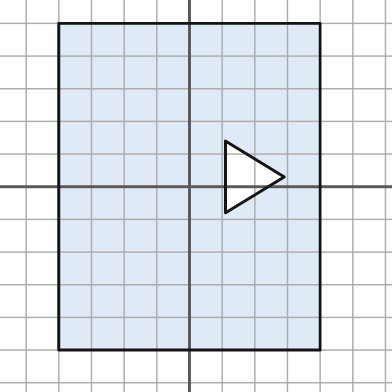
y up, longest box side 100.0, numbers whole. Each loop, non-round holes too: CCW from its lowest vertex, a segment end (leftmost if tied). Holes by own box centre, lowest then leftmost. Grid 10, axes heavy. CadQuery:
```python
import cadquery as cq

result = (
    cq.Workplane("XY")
    .moveTo(-40.0, -50.0)
    .lineTo(40.0, -50.0)
    .lineTo(40.0, 50.0)
    .lineTo(-40.0, 50.0)
    .close()
    .moveTo(11.0, -8.0)
    .lineTo(29.0, 3.0)
    .lineTo(11.0, 14.0)
    .close()
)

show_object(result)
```